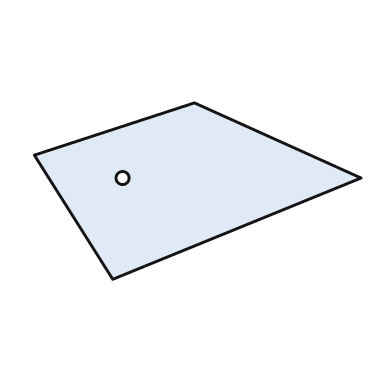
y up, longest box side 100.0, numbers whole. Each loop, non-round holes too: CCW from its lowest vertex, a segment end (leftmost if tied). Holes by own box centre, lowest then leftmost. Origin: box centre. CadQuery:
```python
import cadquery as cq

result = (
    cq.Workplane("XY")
    .moveTo(-26.0, -27.0)
    .lineTo(50.0, 4.0)
    .lineTo(-1.0, 27.0)
    .lineTo(-50.0, 11.0)
    .close()
    .moveTo(-23.0, 4.0)
    .circle(2.0)
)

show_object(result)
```